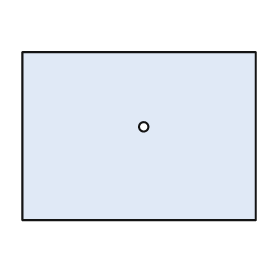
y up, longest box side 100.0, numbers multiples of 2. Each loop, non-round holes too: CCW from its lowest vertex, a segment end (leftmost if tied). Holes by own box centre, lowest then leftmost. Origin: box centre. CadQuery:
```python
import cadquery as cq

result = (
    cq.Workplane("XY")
    .moveTo(-50.0, -36.0)
    .lineTo(50.0, -36.0)
    .lineTo(50.0, 36.0)
    .lineTo(-50.0, 36.0)
    .close()
    .moveTo(2.0, 4.0)
    .circle(2.0)
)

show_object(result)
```